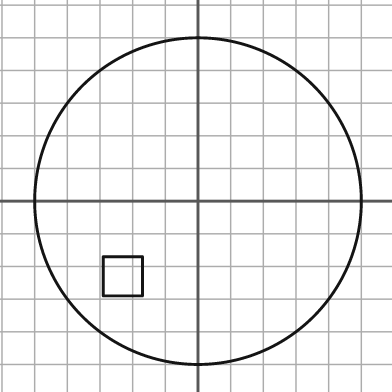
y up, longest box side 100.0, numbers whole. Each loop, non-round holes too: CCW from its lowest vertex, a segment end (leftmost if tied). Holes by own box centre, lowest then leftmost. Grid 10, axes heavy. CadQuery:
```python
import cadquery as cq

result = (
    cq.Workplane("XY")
    .moveTo(0.0, 0.0)
    .circle(50.0)
    .moveTo(-29.0, -29.0)
    .lineTo(-17.0, -29.0)
    .lineTo(-17.0, -17.0)
    .lineTo(-29.0, -17.0)
    .close()
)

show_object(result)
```